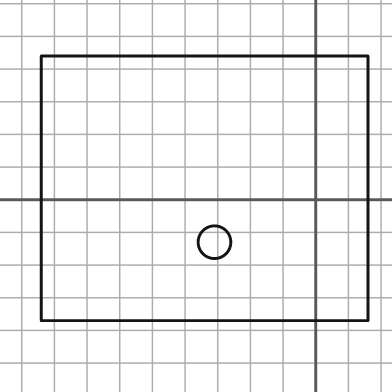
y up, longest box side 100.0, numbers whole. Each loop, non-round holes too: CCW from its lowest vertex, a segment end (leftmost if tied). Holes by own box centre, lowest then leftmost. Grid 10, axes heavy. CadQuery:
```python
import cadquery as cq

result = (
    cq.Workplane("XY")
    .moveTo(-84.0, -37.0)
    .lineTo(16.0, -37.0)
    .lineTo(16.0, 44.0)
    .lineTo(-84.0, 44.0)
    .close()
    .moveTo(-31.0, -13.0)
    .circle(5.0)
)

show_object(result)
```